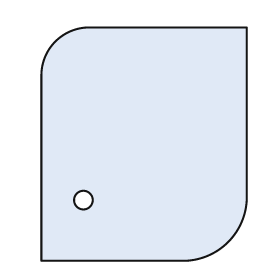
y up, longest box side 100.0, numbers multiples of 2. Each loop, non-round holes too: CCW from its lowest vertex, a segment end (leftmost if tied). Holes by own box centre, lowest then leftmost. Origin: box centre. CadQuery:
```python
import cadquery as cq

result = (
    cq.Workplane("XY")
    .moveTo(-44.0, -50.0)
    .lineTo(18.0, -50.0)
    .threePointArc((36.0, -42.0), (44.0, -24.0))
    .lineTo(44.0, 50.0)
    .lineTo(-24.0, 50.0)
    .threePointArc((-38.0, 44.0), (-44.0, 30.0))
    .close()
    .moveTo(-26.0, -24.0)
    .circle(4.0)
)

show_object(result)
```